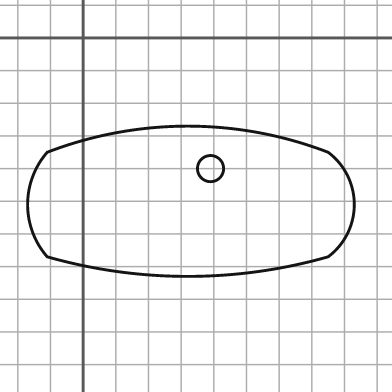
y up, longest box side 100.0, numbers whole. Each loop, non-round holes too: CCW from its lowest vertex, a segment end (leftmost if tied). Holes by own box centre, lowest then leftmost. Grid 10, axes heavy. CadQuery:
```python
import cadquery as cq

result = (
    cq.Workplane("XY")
    .moveTo(-11.0, -67.0)
    .threePointArc((32.0, -73.0), (75.0, -67.0))
    .threePointArc((83.0, -51.0), (75.0, -35.0))
    .threePointArc((32.0, -27.0), (-11.0, -35.0))
    .threePointArc((-17.0, -51.0), (-11.0, -67.0))
    .close()
    .moveTo(39.0, -40.0)
    .circle(4.0)
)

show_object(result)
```